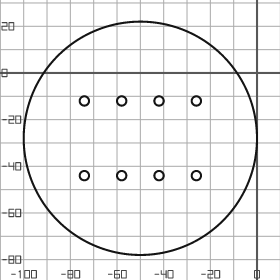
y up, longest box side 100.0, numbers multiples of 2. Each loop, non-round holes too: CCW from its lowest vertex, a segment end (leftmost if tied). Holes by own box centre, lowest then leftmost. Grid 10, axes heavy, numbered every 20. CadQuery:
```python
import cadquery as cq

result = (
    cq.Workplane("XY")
    .moveTo(-50.0, -28.0)
    .circle(50.0)
    .moveTo(-74.0, -44.0)
    .circle(2.0)
    .moveTo(-58.0, -44.0)
    .circle(2.0)
    .moveTo(-42.0, -44.0)
    .circle(2.0)
    .moveTo(-26.0, -44.0)
    .circle(2.0)
    .moveTo(-74.0, -12.0)
    .circle(2.0)
    .moveTo(-58.0, -12.0)
    .circle(2.0)
    .moveTo(-42.0, -12.0)
    .circle(2.0)
    .moveTo(-26.0, -12.0)
    .circle(2.0)
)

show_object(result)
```